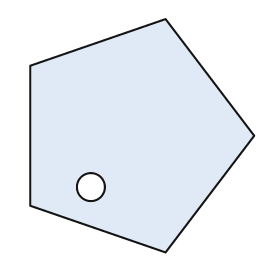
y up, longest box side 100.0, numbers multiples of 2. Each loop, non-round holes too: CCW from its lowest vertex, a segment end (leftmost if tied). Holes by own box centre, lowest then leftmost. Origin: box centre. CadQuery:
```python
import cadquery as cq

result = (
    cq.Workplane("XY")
    .moveTo(10.0, -50.0)
    .lineTo(48.0, 0.0)
    .lineTo(10.0, 50.0)
    .lineTo(-48.0, 30.0)
    .lineTo(-48.0, -30.0)
    .close()
    .moveTo(-22.0, -22.0)
    .circle(6.0)
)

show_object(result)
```